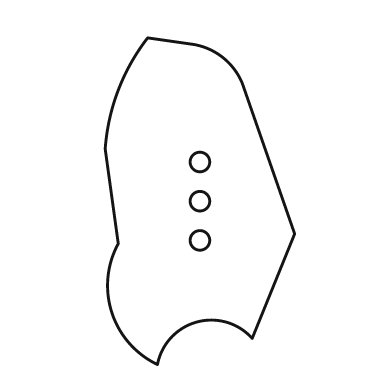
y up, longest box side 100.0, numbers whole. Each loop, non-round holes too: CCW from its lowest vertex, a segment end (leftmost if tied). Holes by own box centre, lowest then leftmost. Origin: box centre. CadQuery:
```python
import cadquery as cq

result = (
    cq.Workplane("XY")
    .moveTo(-13.0, -50.0)
    .threePointArc((-1.0, -37.0), (16.0, -42.0))
    .lineTo(29.0, -10.0)
    .lineTo(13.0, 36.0)
    .threePointArc((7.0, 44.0), (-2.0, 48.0))
    .lineTo(-16.0, 50.0)
    .threePointArc((-25.0, 34.0), (-29.0, 16.0))
    .lineTo(-25.0, -13.0)
    .threePointArc((-27.0, -34.0), (-13.0, -50.0))
    .close()
    .moveTo(0.0, -12.0)
    .circle(3.0)
    .moveTo(0.0, 0.0)
    .circle(3.0)
    .moveTo(0.0, 12.0)
    .circle(3.0)
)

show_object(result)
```